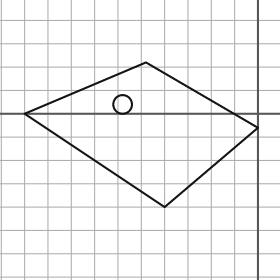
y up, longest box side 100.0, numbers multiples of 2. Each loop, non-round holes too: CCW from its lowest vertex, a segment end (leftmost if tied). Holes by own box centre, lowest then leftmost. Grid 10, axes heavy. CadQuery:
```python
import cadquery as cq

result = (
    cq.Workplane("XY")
    .moveTo(-40.0, -40.0)
    .lineTo(0.0, -6.0)
    .lineTo(-48.0, 22.0)
    .lineTo(-100.0, 0.0)
    .close()
    .moveTo(-58.0, 4.0)
    .circle(4.0)
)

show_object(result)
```